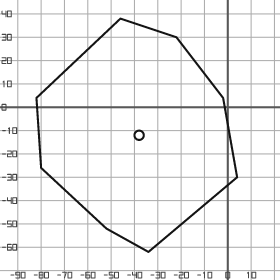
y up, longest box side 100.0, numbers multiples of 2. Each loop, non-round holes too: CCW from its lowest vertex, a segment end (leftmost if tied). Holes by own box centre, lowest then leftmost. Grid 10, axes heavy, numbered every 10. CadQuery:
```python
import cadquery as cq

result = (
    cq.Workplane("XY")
    .moveTo(-34.0, -62.0)
    .lineTo(4.0, -30.0)
    .lineTo(-2.0, 4.0)
    .lineTo(-22.0, 30.0)
    .lineTo(-46.0, 38.0)
    .lineTo(-82.0, 4.0)
    .lineTo(-80.0, -26.0)
    .lineTo(-52.0, -52.0)
    .close()
    .moveTo(-38.0, -12.0)
    .circle(2.0)
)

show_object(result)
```